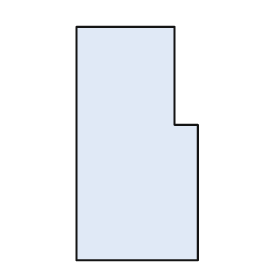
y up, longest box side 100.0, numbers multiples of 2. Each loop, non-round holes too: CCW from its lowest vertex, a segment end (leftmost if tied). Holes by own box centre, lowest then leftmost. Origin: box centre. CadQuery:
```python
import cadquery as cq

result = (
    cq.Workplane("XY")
    .moveTo(-26.0, -50.0)
    .lineTo(26.0, -50.0)
    .lineTo(26.0, 8.0)
    .lineTo(16.0, 8.0)
    .lineTo(16.0, 50.0)
    .lineTo(-26.0, 50.0)
    .close()
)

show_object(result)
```